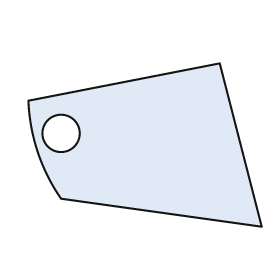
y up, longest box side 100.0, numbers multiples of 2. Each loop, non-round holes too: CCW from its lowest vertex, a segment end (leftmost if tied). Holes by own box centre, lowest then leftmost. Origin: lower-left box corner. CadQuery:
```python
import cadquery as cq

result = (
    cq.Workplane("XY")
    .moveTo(100.0, 0.0)
    .lineTo(82.0, 70.0)
    .lineTo(0.0, 54.0)
    .threePointArc((4.0, 32.0), (14.0, 12.0))
    .close()
    .moveTo(14.0, 40.0)
    .circle(8.0)
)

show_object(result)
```